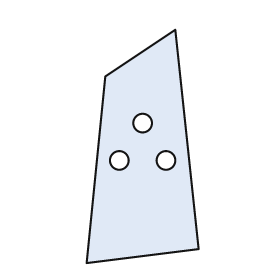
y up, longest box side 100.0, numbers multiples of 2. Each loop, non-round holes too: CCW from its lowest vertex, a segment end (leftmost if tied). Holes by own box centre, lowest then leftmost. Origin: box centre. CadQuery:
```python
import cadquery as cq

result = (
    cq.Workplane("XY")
    .moveTo(-24.0, -50.0)
    .lineTo(24.0, -44.0)
    .lineTo(14.0, 50.0)
    .lineTo(-16.0, 30.0)
    .close()
    .moveTo(-10.0, -6.0)
    .circle(4.0)
    .moveTo(10.0, -6.0)
    .circle(4.0)
    .moveTo(0.0, 10.0)
    .circle(4.0)
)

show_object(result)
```